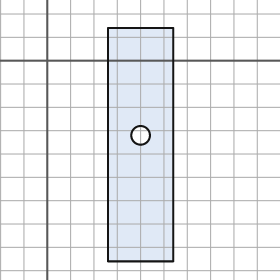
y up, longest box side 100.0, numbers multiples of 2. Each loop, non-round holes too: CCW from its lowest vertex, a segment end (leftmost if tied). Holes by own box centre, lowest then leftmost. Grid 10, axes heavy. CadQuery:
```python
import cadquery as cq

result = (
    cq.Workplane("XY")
    .moveTo(26.0, -86.0)
    .lineTo(54.0, -86.0)
    .lineTo(54.0, 14.0)
    .lineTo(26.0, 14.0)
    .close()
    .moveTo(40.0, -32.0)
    .circle(4.0)
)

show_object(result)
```